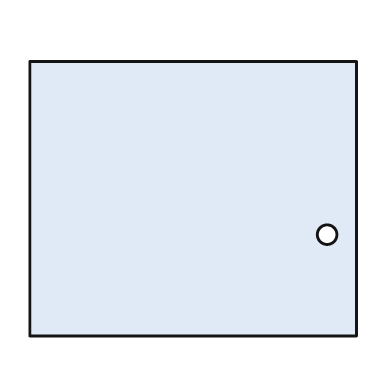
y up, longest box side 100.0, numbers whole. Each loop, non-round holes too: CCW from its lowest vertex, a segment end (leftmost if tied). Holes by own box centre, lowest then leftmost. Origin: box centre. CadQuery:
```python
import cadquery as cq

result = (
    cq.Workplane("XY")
    .moveTo(-50.0, -42.0)
    .lineTo(50.0, -42.0)
    .lineTo(50.0, 42.0)
    .lineTo(-50.0, 42.0)
    .close()
    .moveTo(41.0, -11.0)
    .circle(3.0)
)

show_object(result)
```